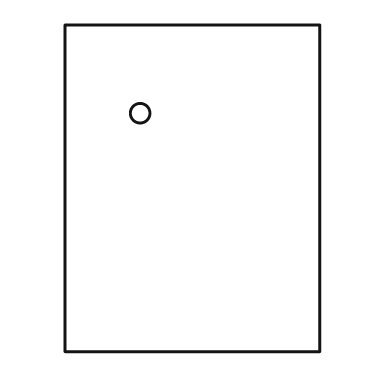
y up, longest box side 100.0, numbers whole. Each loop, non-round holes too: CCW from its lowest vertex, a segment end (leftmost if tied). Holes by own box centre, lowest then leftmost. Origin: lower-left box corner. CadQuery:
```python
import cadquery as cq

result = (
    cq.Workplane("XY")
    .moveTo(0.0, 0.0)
    .lineTo(78.0, 0.0)
    .lineTo(78.0, 100.0)
    .lineTo(0.0, 100.0)
    .close()
    .moveTo(23.0, 73.0)
    .circle(3.0)
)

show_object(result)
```